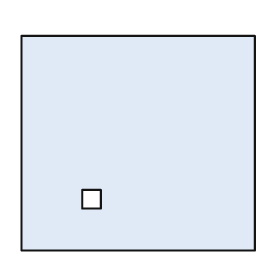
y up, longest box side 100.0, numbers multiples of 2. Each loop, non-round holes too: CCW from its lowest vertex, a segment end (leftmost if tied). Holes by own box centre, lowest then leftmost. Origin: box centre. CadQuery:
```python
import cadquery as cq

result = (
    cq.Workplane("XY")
    .moveTo(-50.0, -46.0)
    .lineTo(50.0, -46.0)
    .lineTo(50.0, 46.0)
    .lineTo(-50.0, 46.0)
    .close()
    .moveTo(-24.0, -28.0)
    .lineTo(-16.0, -28.0)
    .lineTo(-16.0, -20.0)
    .lineTo(-24.0, -20.0)
    .close()
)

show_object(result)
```